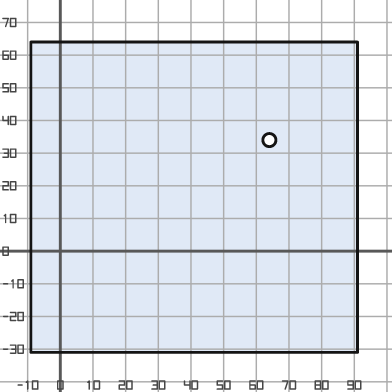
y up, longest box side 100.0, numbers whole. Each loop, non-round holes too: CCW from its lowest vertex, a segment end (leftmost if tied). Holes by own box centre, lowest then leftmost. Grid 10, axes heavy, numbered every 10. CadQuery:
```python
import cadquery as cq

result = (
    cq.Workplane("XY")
    .moveTo(-9.0, -31.0)
    .lineTo(91.0, -31.0)
    .lineTo(91.0, 64.0)
    .lineTo(-9.0, 64.0)
    .close()
    .moveTo(64.0, 34.0)
    .circle(2.0)
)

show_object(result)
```